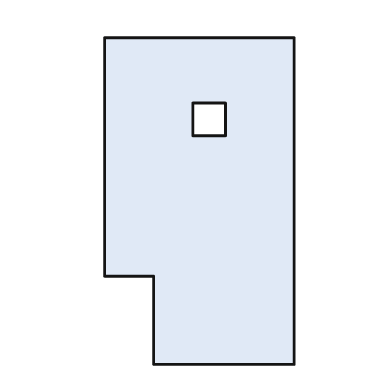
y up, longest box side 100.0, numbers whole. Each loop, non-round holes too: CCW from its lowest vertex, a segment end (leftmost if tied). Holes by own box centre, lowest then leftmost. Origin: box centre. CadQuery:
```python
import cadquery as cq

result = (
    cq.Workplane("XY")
    .moveTo(-14.0, -50.0)
    .lineTo(29.0, -50.0)
    .lineTo(29.0, 50.0)
    .lineTo(-29.0, 50.0)
    .lineTo(-29.0, -23.0)
    .lineTo(-14.0, -23.0)
    .close()
    .moveTo(-2.0, 20.0)
    .lineTo(8.0, 20.0)
    .lineTo(8.0, 30.0)
    .lineTo(-2.0, 30.0)
    .close()
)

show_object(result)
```